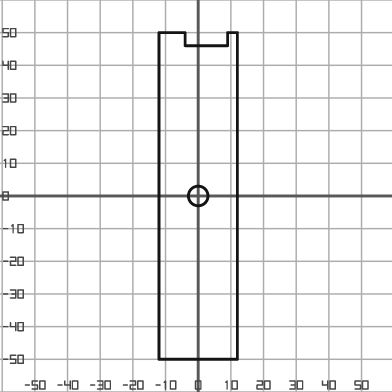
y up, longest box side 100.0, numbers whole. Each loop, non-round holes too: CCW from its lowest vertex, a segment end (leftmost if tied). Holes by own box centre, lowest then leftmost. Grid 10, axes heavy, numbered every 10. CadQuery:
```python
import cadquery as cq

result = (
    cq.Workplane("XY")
    .moveTo(-12.0, -50.0)
    .lineTo(12.0, -50.0)
    .lineTo(12.0, 50.0)
    .lineTo(9.0, 50.0)
    .lineTo(9.0, 46.0)
    .lineTo(-4.0, 46.0)
    .lineTo(-4.0, 50.0)
    .lineTo(-12.0, 50.0)
    .close()
    .moveTo(0.0, 0.0)
    .circle(3.0)
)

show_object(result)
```